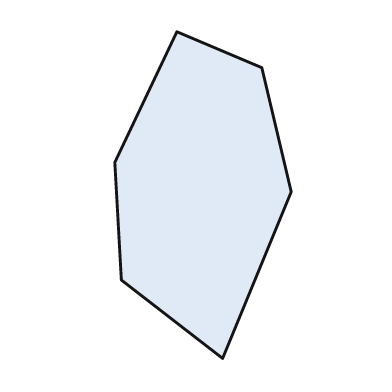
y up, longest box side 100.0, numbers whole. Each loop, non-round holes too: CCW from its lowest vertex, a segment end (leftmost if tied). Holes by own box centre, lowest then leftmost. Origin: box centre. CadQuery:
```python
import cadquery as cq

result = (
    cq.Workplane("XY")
    .moveTo(6.0, -50.0)
    .lineTo(27.0, 1.0)
    .lineTo(18.0, 39.0)
    .lineTo(-8.0, 50.0)
    .lineTo(-27.0, 10.0)
    .lineTo(-25.0, -26.0)
    .close()
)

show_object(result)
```